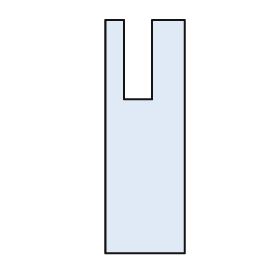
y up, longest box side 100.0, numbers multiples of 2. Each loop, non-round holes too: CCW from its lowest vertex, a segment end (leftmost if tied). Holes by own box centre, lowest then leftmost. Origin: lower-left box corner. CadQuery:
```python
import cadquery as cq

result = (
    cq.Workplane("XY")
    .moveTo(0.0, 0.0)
    .lineTo(34.0, 0.0)
    .lineTo(34.0, 100.0)
    .lineTo(20.0, 100.0)
    .lineTo(20.0, 66.0)
    .lineTo(8.0, 66.0)
    .lineTo(8.0, 100.0)
    .lineTo(0.0, 100.0)
    .close()
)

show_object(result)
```